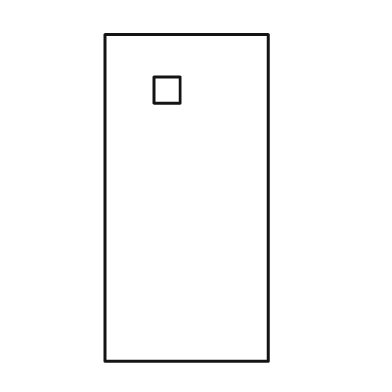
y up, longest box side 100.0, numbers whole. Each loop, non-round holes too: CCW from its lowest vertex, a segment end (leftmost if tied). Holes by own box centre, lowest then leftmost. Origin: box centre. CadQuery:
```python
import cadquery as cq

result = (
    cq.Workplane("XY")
    .moveTo(-25.0, -50.0)
    .lineTo(25.0, -50.0)
    .lineTo(25.0, 50.0)
    .lineTo(-25.0, 50.0)
    .close()
    .moveTo(-10.0, 29.0)
    .lineTo(-2.0, 29.0)
    .lineTo(-2.0, 37.0)
    .lineTo(-10.0, 37.0)
    .close()
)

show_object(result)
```